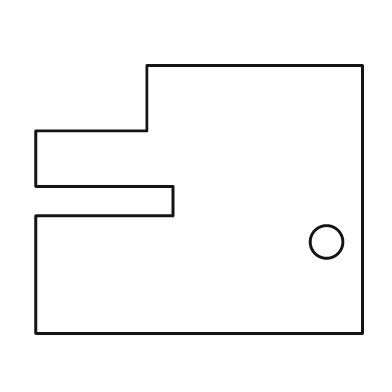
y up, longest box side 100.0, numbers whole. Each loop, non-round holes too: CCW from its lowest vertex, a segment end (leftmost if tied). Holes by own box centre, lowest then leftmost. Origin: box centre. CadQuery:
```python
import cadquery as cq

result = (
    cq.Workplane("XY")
    .moveTo(-50.0, -41.0)
    .lineTo(50.0, -41.0)
    .lineTo(50.0, 41.0)
    .lineTo(-16.0, 41.0)
    .lineTo(-16.0, 21.0)
    .lineTo(-50.0, 21.0)
    .lineTo(-50.0, 4.0)
    .lineTo(-8.0, 4.0)
    .lineTo(-8.0, -5.0)
    .lineTo(-50.0, -5.0)
    .close()
    .moveTo(39.0, -13.0)
    .circle(5.0)
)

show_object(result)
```